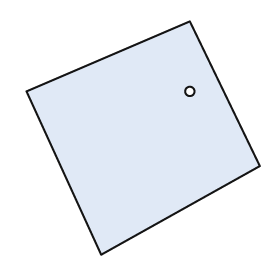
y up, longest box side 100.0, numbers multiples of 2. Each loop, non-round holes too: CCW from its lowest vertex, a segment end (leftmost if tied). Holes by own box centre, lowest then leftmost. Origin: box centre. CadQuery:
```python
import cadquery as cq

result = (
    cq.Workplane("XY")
    .moveTo(-18.0, -50.0)
    .lineTo(50.0, -12.0)
    .lineTo(20.0, 50.0)
    .lineTo(-50.0, 20.0)
    .close()
    .moveTo(20.0, 20.0)
    .circle(2.0)
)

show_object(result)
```